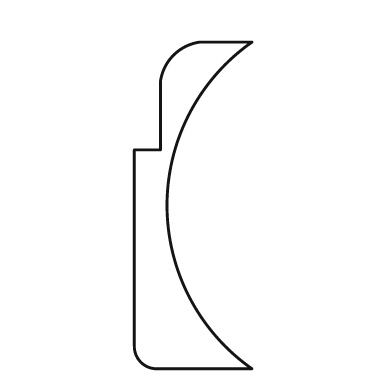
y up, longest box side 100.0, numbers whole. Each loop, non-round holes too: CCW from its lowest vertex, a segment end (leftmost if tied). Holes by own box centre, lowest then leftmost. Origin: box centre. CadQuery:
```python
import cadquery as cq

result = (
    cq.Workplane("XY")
    .moveTo(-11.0, -50.0)
    .lineTo(18.0, -50.0)
    .threePointArc((-8.0, 0.0), (18.0, 50.0))
    .lineTo(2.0, 50.0)
    .threePointArc((-6.0, 46.0), (-10.0, 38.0))
    .lineTo(-10.0, 17.0)
    .lineTo(-18.0, 17.0)
    .lineTo(-18.0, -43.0)
    .threePointArc((-16.0, -48.0), (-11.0, -50.0))
    .close()
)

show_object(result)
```